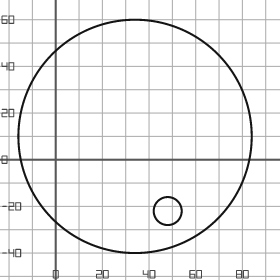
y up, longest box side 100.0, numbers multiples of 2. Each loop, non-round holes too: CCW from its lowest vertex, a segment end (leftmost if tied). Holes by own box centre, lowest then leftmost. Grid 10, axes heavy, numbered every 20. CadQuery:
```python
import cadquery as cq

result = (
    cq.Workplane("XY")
    .moveTo(34.0, 10.0)
    .circle(50.0)
    .moveTo(48.0, -22.0)
    .circle(6.0)
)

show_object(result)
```